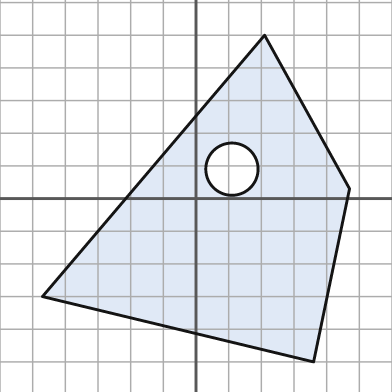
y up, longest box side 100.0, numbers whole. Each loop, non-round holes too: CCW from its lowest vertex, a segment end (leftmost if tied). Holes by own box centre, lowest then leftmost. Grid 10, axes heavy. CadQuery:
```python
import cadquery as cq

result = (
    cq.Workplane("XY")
    .moveTo(36.0, -50.0)
    .lineTo(47.0, 3.0)
    .lineTo(21.0, 50.0)
    .lineTo(-47.0, -30.0)
    .close()
    .moveTo(11.0, 9.0)
    .circle(8.0)
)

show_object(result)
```